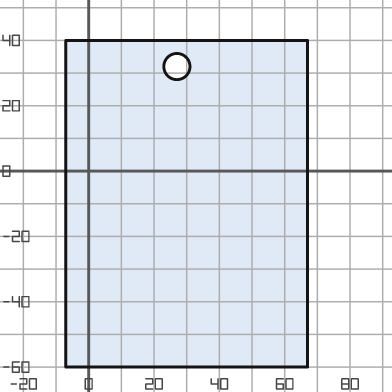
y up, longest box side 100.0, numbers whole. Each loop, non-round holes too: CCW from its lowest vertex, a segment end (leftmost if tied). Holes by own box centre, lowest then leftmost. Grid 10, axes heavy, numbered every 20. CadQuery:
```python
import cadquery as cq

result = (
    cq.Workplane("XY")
    .moveTo(-7.0, -60.0)
    .lineTo(67.0, -60.0)
    .lineTo(67.0, 40.0)
    .lineTo(-7.0, 40.0)
    .close()
    .moveTo(27.0, 32.0)
    .circle(4.0)
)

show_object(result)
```